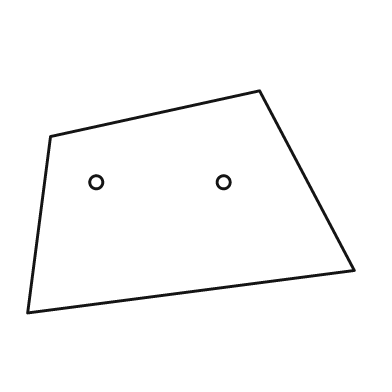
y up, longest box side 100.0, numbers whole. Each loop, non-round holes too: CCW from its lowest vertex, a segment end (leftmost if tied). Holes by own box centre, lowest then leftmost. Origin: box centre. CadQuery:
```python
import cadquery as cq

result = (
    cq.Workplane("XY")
    .moveTo(-50.0, -34.0)
    .lineTo(50.0, -21.0)
    .lineTo(21.0, 34.0)
    .lineTo(-43.0, 20.0)
    .close()
    .moveTo(-29.0, 6.0)
    .circle(2.0)
    .moveTo(10.0, 6.0)
    .circle(2.0)
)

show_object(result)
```